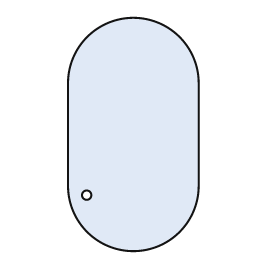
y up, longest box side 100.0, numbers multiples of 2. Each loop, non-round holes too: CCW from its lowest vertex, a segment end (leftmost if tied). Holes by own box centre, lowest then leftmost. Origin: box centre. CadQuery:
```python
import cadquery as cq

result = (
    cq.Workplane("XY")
    .moveTo(-28.0, -22.0)
    .threePointArc((0.0, -50.0), (28.0, -22.0))
    .lineTo(28.0, 22.0)
    .threePointArc((0.0, 50.0), (-28.0, 22.0))
    .close()
    .moveTo(-20.0, -26.0)
    .circle(2.0)
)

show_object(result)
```